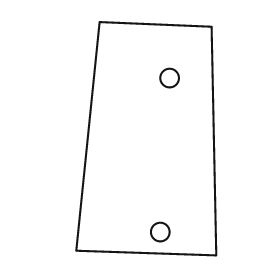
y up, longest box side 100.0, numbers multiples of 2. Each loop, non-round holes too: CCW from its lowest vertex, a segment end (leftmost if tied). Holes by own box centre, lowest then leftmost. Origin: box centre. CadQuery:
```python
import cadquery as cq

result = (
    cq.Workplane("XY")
    .moveTo(30.0, -50.0)
    .lineTo(28.0, 48.0)
    .lineTo(-20.0, 50.0)
    .lineTo(-30.0, -48.0)
    .close()
    .moveTo(6.0, -40.0)
    .circle(4.0)
    .moveTo(10.0, 26.0)
    .circle(4.0)
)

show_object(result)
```